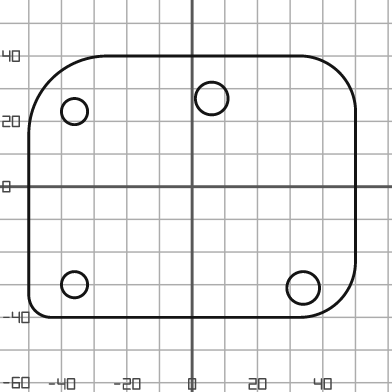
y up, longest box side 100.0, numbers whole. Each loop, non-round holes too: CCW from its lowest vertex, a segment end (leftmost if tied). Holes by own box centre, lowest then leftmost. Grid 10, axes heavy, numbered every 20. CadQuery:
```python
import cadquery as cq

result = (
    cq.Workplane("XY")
    .moveTo(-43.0, -40.0)
    .lineTo(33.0, -40.0)
    .threePointArc((45.0, -35.0), (50.0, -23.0))
    .lineTo(50.0, 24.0)
    .threePointArc((45.0, 35.0), (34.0, 40.0))
    .lineTo(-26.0, 40.0)
    .threePointArc((-43.0, 33.0), (-50.0, 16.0))
    .lineTo(-50.0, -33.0)
    .threePointArc((-48.0, -38.0), (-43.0, -40.0))
    .close()
    .moveTo(34.0, -31.0)
    .circle(5.0)
    .moveTo(-36.0, -30.0)
    .circle(4.0)
    .moveTo(-36.0, 23.0)
    .circle(4.0)
    .moveTo(6.0, 27.0)
    .circle(5.0)
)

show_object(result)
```